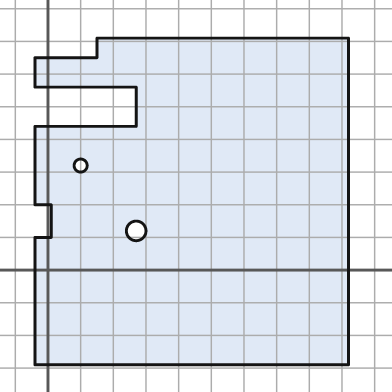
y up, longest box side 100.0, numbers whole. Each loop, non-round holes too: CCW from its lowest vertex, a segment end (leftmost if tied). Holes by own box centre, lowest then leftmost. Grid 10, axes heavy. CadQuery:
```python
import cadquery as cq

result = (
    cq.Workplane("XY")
    .moveTo(-4.0, -29.0)
    .lineTo(92.0, -29.0)
    .lineTo(92.0, 71.0)
    .lineTo(15.0, 71.0)
    .lineTo(15.0, 65.0)
    .lineTo(-4.0, 65.0)
    .lineTo(-4.0, 56.0)
    .lineTo(27.0, 56.0)
    .lineTo(27.0, 44.0)
    .lineTo(-4.0, 44.0)
    .lineTo(-4.0, 20.0)
    .lineTo(1.0, 20.0)
    .lineTo(1.0, 10.0)
    .lineTo(-4.0, 10.0)
    .close()
    .moveTo(27.0, 12.0)
    .circle(3.0)
    .moveTo(10.0, 32.0)
    .circle(2.0)
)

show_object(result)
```